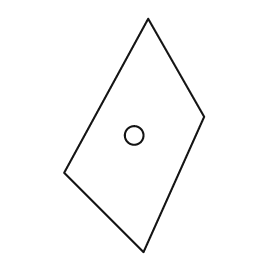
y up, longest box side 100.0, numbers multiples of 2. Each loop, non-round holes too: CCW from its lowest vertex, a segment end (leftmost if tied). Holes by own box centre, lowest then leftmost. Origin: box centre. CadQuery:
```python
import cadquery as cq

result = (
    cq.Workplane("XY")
    .moveTo(4.0, -50.0)
    .lineTo(30.0, 8.0)
    .lineTo(6.0, 50.0)
    .lineTo(-30.0, -16.0)
    .close()
    .moveTo(0.0, 0.0)
    .circle(4.0)
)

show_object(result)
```